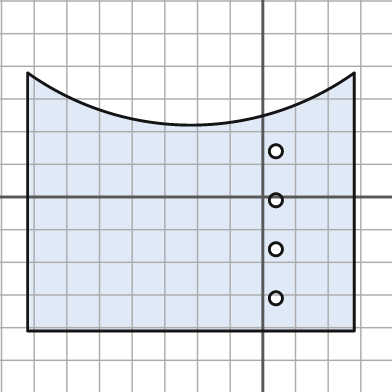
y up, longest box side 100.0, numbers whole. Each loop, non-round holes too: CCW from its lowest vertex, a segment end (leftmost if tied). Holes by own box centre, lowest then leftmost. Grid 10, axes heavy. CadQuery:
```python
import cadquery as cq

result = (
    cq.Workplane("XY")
    .moveTo(-72.0, -41.0)
    .lineTo(28.0, -41.0)
    .lineTo(28.0, 38.0)
    .threePointArc((-22.0, 22.0), (-72.0, 38.0))
    .close()
    .moveTo(4.0, -31.0)
    .circle(2.0)
    .moveTo(4.0, -16.0)
    .circle(2.0)
    .moveTo(4.0, -1.0)
    .circle(2.0)
    .moveTo(4.0, 14.0)
    .circle(2.0)
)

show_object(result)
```